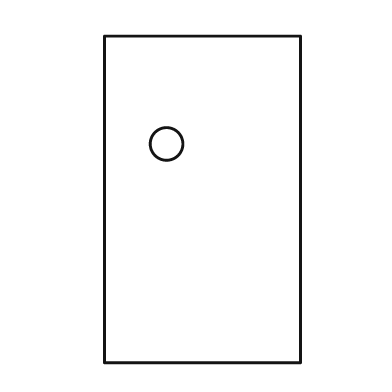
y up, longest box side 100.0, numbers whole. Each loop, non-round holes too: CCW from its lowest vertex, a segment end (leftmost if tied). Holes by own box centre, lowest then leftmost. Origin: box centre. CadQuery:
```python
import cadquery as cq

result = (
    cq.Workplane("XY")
    .moveTo(-30.0, -50.0)
    .lineTo(30.0, -50.0)
    .lineTo(30.0, 50.0)
    .lineTo(-30.0, 50.0)
    .close()
    .moveTo(-11.0, 17.0)
    .circle(5.0)
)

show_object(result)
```